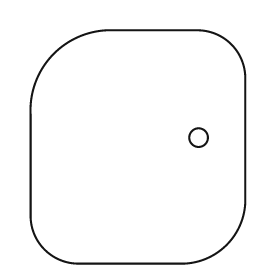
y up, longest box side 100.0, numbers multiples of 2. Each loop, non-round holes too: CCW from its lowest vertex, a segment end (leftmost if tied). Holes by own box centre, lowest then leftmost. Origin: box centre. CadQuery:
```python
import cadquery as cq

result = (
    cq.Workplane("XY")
    .moveTo(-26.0, -50.0)
    .lineTo(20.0, -50.0)
    .threePointArc((38.0, -42.0), (46.0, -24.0))
    .lineTo(46.0, 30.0)
    .threePointArc((40.0, 44.0), (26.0, 50.0))
    .lineTo(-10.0, 50.0)
    .threePointArc((-36.0, 40.0), (-46.0, 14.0))
    .lineTo(-46.0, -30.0)
    .threePointArc((-40.0, -44.0), (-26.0, -50.0))
    .close()
    .moveTo(26.0, 4.0)
    .circle(4.0)
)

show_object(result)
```